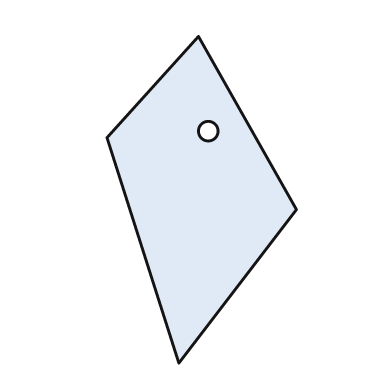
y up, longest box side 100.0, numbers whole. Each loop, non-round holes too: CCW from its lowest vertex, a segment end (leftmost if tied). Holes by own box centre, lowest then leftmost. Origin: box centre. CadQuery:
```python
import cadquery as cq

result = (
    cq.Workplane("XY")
    .moveTo(-7.0, -50.0)
    .lineTo(29.0, -3.0)
    .lineTo(-1.0, 50.0)
    .lineTo(-29.0, 19.0)
    .close()
    .moveTo(2.0, 21.0)
    .circle(3.0)
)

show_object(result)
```